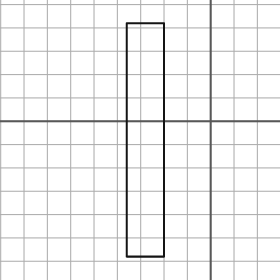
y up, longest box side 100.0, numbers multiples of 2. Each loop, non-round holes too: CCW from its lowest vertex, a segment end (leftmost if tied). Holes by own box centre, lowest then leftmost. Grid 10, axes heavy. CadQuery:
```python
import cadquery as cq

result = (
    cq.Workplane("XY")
    .moveTo(-36.0, -58.0)
    .lineTo(-20.0, -58.0)
    .lineTo(-20.0, 42.0)
    .lineTo(-36.0, 42.0)
    .close()
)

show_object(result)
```